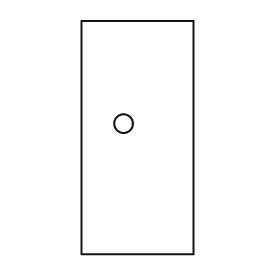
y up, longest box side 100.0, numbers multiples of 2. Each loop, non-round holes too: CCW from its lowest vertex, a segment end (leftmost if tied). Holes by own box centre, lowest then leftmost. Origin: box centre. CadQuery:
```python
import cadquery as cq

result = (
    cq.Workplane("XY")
    .moveTo(-24.0, -50.0)
    .lineTo(24.0, -50.0)
    .lineTo(24.0, 50.0)
    .lineTo(-24.0, 50.0)
    .close()
    .moveTo(-6.0, 6.0)
    .circle(4.0)
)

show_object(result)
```